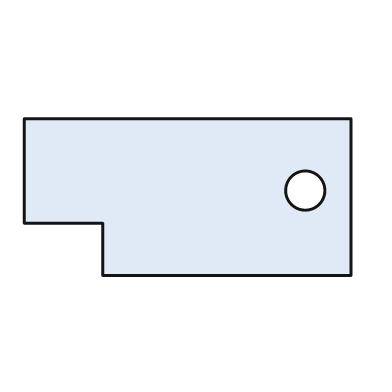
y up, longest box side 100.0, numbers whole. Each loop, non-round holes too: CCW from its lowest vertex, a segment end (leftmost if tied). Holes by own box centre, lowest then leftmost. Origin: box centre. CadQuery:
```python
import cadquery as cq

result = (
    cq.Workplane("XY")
    .moveTo(-26.0, -24.0)
    .lineTo(50.0, -24.0)
    .lineTo(50.0, 24.0)
    .lineTo(-50.0, 24.0)
    .lineTo(-50.0, -8.0)
    .lineTo(-26.0, -8.0)
    .close()
    .moveTo(36.0, 2.0)
    .circle(6.0)
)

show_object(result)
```